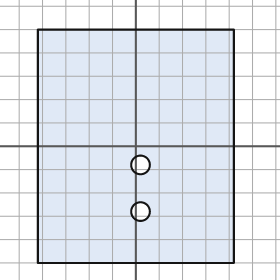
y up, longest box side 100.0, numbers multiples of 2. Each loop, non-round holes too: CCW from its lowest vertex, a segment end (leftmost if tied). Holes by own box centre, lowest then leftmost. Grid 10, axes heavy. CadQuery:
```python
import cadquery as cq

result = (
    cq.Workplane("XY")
    .moveTo(-42.0, -50.0)
    .lineTo(42.0, -50.0)
    .lineTo(42.0, 50.0)
    .lineTo(-42.0, 50.0)
    .close()
    .moveTo(2.0, -28.0)
    .circle(4.0)
    .moveTo(2.0, -8.0)
    .circle(4.0)
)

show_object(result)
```